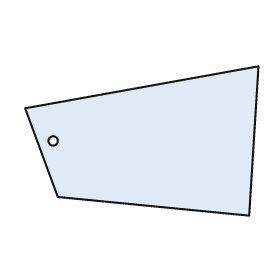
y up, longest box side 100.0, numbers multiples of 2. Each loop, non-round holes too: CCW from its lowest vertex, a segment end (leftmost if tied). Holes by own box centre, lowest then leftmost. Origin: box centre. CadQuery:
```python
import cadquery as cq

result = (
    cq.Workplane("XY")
    .moveTo(46.0, -32.0)
    .lineTo(50.0, 32.0)
    .lineTo(-50.0, 14.0)
    .lineTo(-36.0, -24.0)
    .close()
    .moveTo(-38.0, 0.0)
    .circle(2.0)
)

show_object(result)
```